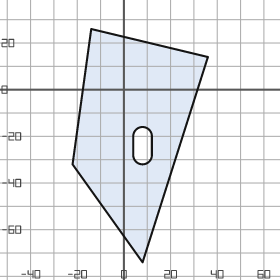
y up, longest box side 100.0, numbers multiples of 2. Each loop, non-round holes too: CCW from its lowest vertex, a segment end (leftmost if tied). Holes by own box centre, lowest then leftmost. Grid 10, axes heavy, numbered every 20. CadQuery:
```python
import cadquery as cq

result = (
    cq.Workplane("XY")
    .moveTo(8.0, -74.0)
    .lineTo(36.0, 14.0)
    .lineTo(-14.0, 26.0)
    .lineTo(-22.0, -32.0)
    .close()
    .moveTo(4.0, -28.0)
    .threePointArc((8.0, -32.0), (12.0, -28.0))
    .lineTo(12.0, -20.0)
    .threePointArc((8.0, -16.0), (4.0, -20.0))
    .close()
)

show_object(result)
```